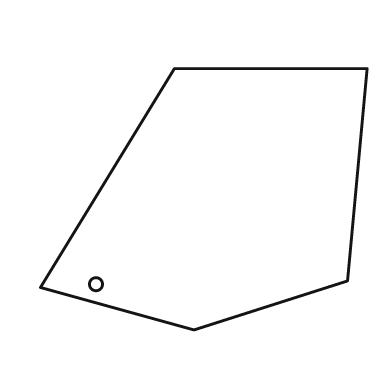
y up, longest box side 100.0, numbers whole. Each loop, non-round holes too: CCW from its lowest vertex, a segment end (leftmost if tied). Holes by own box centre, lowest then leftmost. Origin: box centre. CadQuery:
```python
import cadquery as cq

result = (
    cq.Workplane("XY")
    .moveTo(-3.0, -40.0)
    .lineTo(44.0, -25.0)
    .lineTo(50.0, 40.0)
    .lineTo(-9.0, 40.0)
    .lineTo(-50.0, -27.0)
    .close()
    .moveTo(-33.0, -26.0)
    .circle(2.0)
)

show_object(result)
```